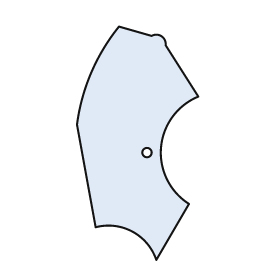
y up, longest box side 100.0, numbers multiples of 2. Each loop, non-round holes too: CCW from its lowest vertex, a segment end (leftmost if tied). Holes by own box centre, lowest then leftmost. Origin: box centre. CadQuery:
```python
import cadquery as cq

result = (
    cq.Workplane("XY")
    .moveTo(8.0, -50.0)
    .lineTo(22.0, -26.0)
    .threePointArc((10.0, -2.0), (26.0, 20.0))
    .lineTo(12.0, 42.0)
    .threePointArc((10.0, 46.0), (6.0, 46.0))
    .lineTo(-8.0, 50.0)
    .threePointArc((-20.0, 30.0), (-26.0, 8.0))
    .lineTo(-18.0, -36.0)
    .threePointArc((-2.0, -38.0), (8.0, -50.0))
    .close()
    .moveTo(4.0, -4.0)
    .circle(2.0)
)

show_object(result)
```